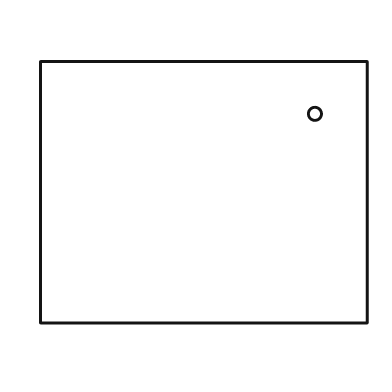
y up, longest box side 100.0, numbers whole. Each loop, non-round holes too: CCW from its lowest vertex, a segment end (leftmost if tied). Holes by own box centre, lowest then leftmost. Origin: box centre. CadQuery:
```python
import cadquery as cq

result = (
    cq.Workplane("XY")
    .moveTo(-50.0, -40.0)
    .lineTo(50.0, -40.0)
    .lineTo(50.0, 40.0)
    .lineTo(-50.0, 40.0)
    .close()
    .moveTo(34.0, 24.0)
    .circle(2.0)
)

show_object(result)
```